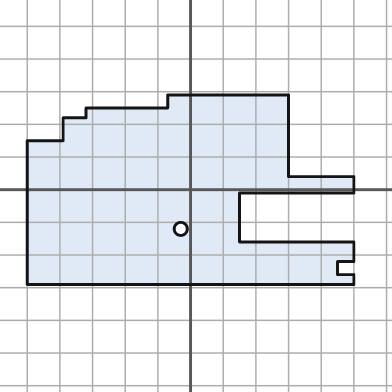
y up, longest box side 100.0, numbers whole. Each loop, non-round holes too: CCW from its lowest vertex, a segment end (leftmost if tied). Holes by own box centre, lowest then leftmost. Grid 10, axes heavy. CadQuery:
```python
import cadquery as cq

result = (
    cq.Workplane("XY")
    .moveTo(-50.0, -29.0)
    .lineTo(50.0, -29.0)
    .lineTo(50.0, -26.0)
    .lineTo(45.0, -26.0)
    .lineTo(45.0, -22.0)
    .lineTo(50.0, -22.0)
    .lineTo(50.0, -16.0)
    .lineTo(15.0, -16.0)
    .lineTo(15.0, -1.0)
    .lineTo(50.0, -1.0)
    .lineTo(50.0, 4.0)
    .lineTo(30.0, 4.0)
    .lineTo(30.0, 29.0)
    .lineTo(-7.0, 29.0)
    .lineTo(-7.0, 25.0)
    .lineTo(-32.0, 25.0)
    .lineTo(-32.0, 22.0)
    .lineTo(-39.0, 22.0)
    .lineTo(-39.0, 15.0)
    .lineTo(-50.0, 15.0)
    .close()
    .moveTo(-3.0, -12.0)
    .circle(2.0)
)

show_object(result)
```